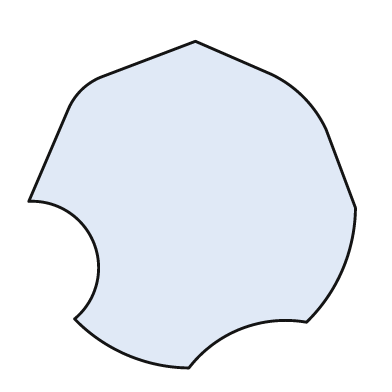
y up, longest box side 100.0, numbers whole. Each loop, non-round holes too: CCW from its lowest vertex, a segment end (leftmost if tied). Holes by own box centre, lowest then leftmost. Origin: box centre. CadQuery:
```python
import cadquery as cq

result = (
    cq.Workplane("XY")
    .moveTo(-1.0, -50.0)
    .threePointArc((15.0, -38.0), (35.0, -36.0))
    .threePointArc((46.0, -20.0), (50.0, -1.0))
    .lineTo(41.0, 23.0)
    .threePointArc((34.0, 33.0), (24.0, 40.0))
    .lineTo(1.0, 50.0)
    .lineTo(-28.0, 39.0)
    .threePointArc((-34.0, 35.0), (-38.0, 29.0))
    .lineTo(-50.0, 1.0)
    .threePointArc((-30.0, -12.0), (-36.0, -35.0))
    .threePointArc((-20.0, -46.0), (-1.0, -50.0))
    .close()
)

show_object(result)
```